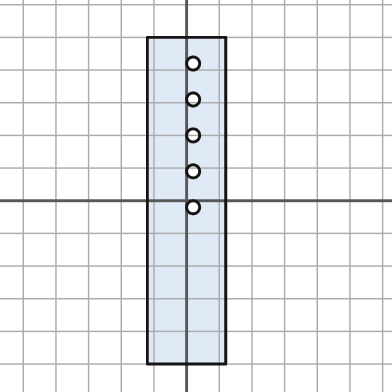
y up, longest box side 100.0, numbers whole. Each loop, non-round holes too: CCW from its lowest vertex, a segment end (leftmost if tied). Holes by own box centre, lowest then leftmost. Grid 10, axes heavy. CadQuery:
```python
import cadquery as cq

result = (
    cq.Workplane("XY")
    .moveTo(-12.0, -50.0)
    .lineTo(12.0, -50.0)
    .lineTo(12.0, 50.0)
    .lineTo(-12.0, 50.0)
    .close()
    .moveTo(2.0, -2.0)
    .circle(2.0)
    .moveTo(2.0, 9.0)
    .circle(2.0)
    .moveTo(2.0, 20.0)
    .circle(2.0)
    .moveTo(2.0, 31.0)
    .circle(2.0)
    .moveTo(2.0, 42.0)
    .circle(2.0)
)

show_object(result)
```